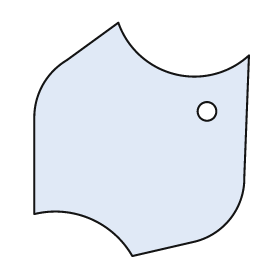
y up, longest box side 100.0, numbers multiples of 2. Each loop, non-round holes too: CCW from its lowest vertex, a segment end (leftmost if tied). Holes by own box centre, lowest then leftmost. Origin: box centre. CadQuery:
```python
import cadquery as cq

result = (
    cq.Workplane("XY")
    .moveTo(-4.0, -50.0)
    .lineTo(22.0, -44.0)
    .threePointArc((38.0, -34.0), (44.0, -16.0))
    .lineTo(46.0, 36.0)
    .threePointArc((14.0, 28.0), (-10.0, 50.0))
    .lineTo(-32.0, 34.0)
    .threePointArc((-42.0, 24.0), (-46.0, 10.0))
    .lineTo(-46.0, -32.0)
    .threePointArc((-22.0, -34.0), (-4.0, -50.0))
    .close()
    .moveTo(28.0, 12.0)
    .circle(4.0)
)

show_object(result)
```